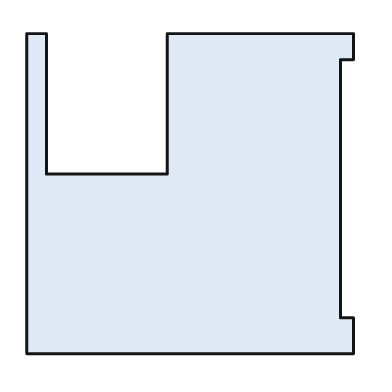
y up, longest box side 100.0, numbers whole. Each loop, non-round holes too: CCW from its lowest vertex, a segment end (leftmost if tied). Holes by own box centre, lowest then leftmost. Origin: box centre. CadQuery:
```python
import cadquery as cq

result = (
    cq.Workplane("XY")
    .moveTo(-50.0, -49.0)
    .lineTo(50.0, -49.0)
    .lineTo(50.0, -38.0)
    .lineTo(46.0, -38.0)
    .lineTo(46.0, 41.0)
    .lineTo(50.0, 41.0)
    .lineTo(50.0, 49.0)
    .lineTo(-7.0, 49.0)
    .lineTo(-7.0, 6.0)
    .lineTo(-44.0, 6.0)
    .lineTo(-44.0, 49.0)
    .lineTo(-50.0, 49.0)
    .close()
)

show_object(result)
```